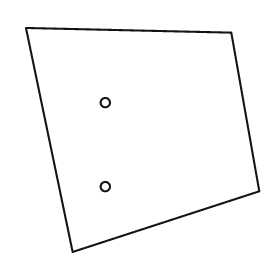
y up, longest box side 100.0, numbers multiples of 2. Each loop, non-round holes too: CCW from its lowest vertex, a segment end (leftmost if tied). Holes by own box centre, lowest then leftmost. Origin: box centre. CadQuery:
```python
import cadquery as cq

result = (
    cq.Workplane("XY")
    .moveTo(-30.0, -48.0)
    .lineTo(50.0, -22.0)
    .lineTo(38.0, 46.0)
    .lineTo(-50.0, 48.0)
    .close()
    .moveTo(-16.0, -20.0)
    .circle(2.0)
    .moveTo(-16.0, 16.0)
    .circle(2.0)
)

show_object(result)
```